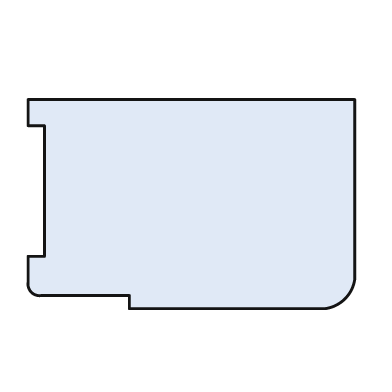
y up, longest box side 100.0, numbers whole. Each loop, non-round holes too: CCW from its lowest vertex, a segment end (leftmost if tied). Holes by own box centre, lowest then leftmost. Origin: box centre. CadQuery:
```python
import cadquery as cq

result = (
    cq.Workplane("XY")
    .moveTo(-19.0, -32.0)
    .lineTo(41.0, -32.0)
    .threePointArc((47.0, -29.0), (50.0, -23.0))
    .lineTo(50.0, 32.0)
    .lineTo(-50.0, 32.0)
    .lineTo(-50.0, 24.0)
    .lineTo(-45.0, 24.0)
    .lineTo(-45.0, -16.0)
    .lineTo(-50.0, -16.0)
    .lineTo(-50.0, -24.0)
    .threePointArc((-49.0, -27.0), (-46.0, -28.0))
    .lineTo(-19.0, -28.0)
    .close()
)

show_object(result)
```